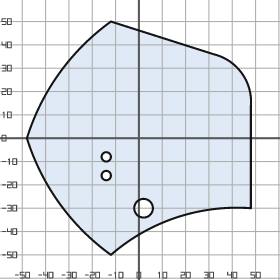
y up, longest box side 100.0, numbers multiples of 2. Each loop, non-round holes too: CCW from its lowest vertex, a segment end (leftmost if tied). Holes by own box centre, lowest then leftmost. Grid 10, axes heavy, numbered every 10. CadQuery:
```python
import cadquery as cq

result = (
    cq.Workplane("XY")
    .moveTo(-12.0, -50.0)
    .threePointArc((16.0, -34.0), (48.0, -30.0))
    .lineTo(48.0, 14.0)
    .threePointArc((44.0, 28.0), (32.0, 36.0))
    .lineTo(-12.0, 50.0)
    .threePointArc((-34.0, 28.0), (-48.0, 0.0))
    .threePointArc((-34.0, -28.0), (-12.0, -50.0))
    .close()
    .moveTo(2.0, -30.0)
    .circle(4.0)
    .moveTo(-14.0, -16.0)
    .circle(2.0)
    .moveTo(-14.0, -8.0)
    .circle(2.0)
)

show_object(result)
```